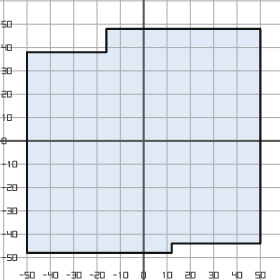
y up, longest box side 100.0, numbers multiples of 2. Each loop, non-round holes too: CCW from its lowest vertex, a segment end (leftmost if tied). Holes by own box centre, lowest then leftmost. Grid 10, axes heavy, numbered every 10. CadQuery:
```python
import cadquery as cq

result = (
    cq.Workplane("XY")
    .moveTo(-50.0, -48.0)
    .lineTo(12.0, -48.0)
    .lineTo(12.0, -44.0)
    .lineTo(50.0, -44.0)
    .lineTo(50.0, 48.0)
    .lineTo(-16.0, 48.0)
    .lineTo(-16.0, 38.0)
    .lineTo(-50.0, 38.0)
    .close()
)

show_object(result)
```